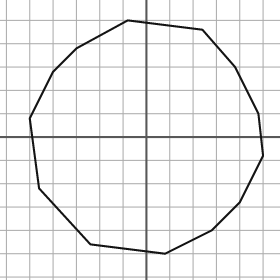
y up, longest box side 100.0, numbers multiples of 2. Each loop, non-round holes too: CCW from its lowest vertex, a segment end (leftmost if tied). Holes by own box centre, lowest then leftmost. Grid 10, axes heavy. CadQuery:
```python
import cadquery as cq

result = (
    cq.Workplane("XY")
    .moveTo(8.0, -50.0)
    .lineTo(28.0, -40.0)
    .lineTo(40.0, -28.0)
    .lineTo(50.0, -8.0)
    .lineTo(48.0, 10.0)
    .lineTo(38.0, 30.0)
    .lineTo(24.0, 46.0)
    .lineTo(-8.0, 50.0)
    .lineTo(-30.0, 38.0)
    .lineTo(-40.0, 28.0)
    .lineTo(-50.0, 8.0)
    .lineTo(-46.0, -22.0)
    .lineTo(-24.0, -46.0)
    .close()
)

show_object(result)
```